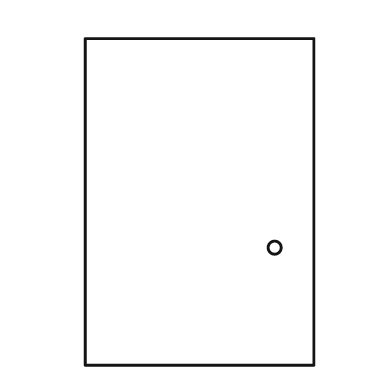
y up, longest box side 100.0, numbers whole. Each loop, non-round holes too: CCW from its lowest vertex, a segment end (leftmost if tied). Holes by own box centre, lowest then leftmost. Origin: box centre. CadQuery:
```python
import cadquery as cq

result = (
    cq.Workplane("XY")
    .moveTo(-35.0, -50.0)
    .lineTo(35.0, -50.0)
    .lineTo(35.0, 50.0)
    .lineTo(-35.0, 50.0)
    .close()
    .moveTo(23.0, -14.0)
    .circle(2.0)
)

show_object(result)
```